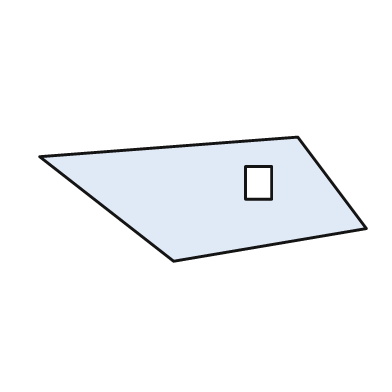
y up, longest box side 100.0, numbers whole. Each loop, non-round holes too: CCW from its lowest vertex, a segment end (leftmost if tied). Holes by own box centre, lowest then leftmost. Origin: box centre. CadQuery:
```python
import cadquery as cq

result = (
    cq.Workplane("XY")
    .moveTo(-9.0, -19.0)
    .lineTo(50.0, -9.0)
    .lineTo(29.0, 19.0)
    .lineTo(-50.0, 13.0)
    .close()
    .moveTo(13.0, 0.0)
    .lineTo(21.0, 0.0)
    .lineTo(21.0, 10.0)
    .lineTo(13.0, 10.0)
    .close()
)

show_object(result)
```